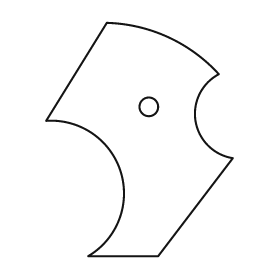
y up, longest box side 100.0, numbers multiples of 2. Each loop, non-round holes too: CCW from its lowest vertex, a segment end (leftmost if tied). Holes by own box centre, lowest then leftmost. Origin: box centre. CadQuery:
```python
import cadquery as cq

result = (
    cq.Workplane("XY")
    .moveTo(-22.0, -50.0)
    .lineTo(8.0, -50.0)
    .lineTo(40.0, -8.0)
    .threePointArc((24.0, 8.0), (34.0, 28.0))
    .threePointArc((12.0, 44.0), (-14.0, 50.0))
    .lineTo(-40.0, 8.0)
    .threePointArc((-8.0, -14.0), (-22.0, -50.0))
    .close()
    .moveTo(4.0, 14.0)
    .circle(4.0)
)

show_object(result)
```